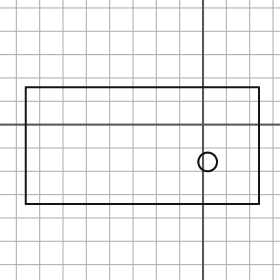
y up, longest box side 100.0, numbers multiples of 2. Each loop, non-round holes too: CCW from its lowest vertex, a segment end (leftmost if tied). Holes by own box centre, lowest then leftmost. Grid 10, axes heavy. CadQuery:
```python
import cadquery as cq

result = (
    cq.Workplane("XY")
    .moveTo(-76.0, -34.0)
    .lineTo(24.0, -34.0)
    .lineTo(24.0, 16.0)
    .lineTo(-76.0, 16.0)
    .close()
    .moveTo(2.0, -16.0)
    .circle(4.0)
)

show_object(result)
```